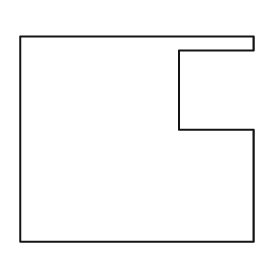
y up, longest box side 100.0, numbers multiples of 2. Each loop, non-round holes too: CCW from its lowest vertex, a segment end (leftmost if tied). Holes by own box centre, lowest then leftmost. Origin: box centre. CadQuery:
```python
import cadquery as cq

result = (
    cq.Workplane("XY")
    .moveTo(-50.0, -44.0)
    .lineTo(50.0, -44.0)
    .lineTo(50.0, 4.0)
    .lineTo(18.0, 4.0)
    .lineTo(18.0, 38.0)
    .lineTo(50.0, 38.0)
    .lineTo(50.0, 44.0)
    .lineTo(-50.0, 44.0)
    .close()
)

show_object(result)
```